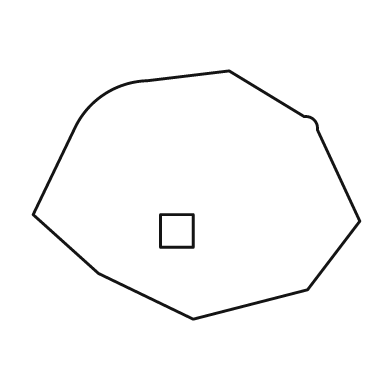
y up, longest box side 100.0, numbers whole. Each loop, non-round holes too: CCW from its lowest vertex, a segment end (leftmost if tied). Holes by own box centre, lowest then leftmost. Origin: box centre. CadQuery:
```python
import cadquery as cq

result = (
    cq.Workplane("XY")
    .moveTo(-1.0, -38.0)
    .lineTo(34.0, -29.0)
    .lineTo(50.0, -8.0)
    .lineTo(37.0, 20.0)
    .threePointArc((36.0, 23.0), (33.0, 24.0))
    .lineTo(10.0, 38.0)
    .lineTo(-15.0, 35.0)
    .threePointArc((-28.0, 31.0), (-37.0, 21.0))
    .lineTo(-50.0, -6.0)
    .lineTo(-30.0, -24.0)
    .close()
    .moveTo(-11.0, -16.0)
    .lineTo(-1.0, -16.0)
    .lineTo(-1.0, -6.0)
    .lineTo(-11.0, -6.0)
    .close()
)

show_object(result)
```